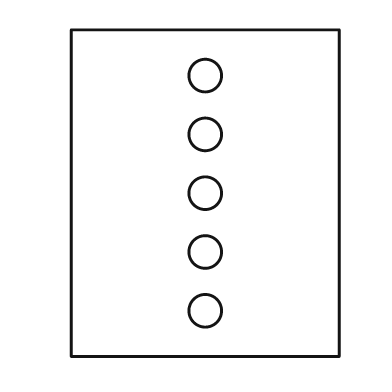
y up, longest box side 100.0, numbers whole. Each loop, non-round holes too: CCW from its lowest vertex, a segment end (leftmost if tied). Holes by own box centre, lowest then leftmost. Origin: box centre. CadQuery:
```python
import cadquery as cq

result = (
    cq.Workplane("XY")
    .moveTo(-41.0, -50.0)
    .lineTo(41.0, -50.0)
    .lineTo(41.0, 50.0)
    .lineTo(-41.0, 50.0)
    .close()
    .moveTo(0.0, -36.0)
    .circle(5.0)
    .moveTo(0.0, -18.0)
    .circle(5.0)
    .moveTo(0.0, 0.0)
    .circle(5.0)
    .moveTo(0.0, 18.0)
    .circle(5.0)
    .moveTo(0.0, 36.0)
    .circle(5.0)
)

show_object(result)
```